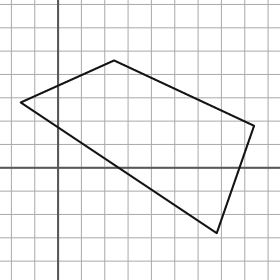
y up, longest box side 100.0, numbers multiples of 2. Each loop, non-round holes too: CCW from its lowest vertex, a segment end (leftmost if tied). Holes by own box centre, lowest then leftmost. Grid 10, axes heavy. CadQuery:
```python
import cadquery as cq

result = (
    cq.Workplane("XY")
    .moveTo(68.0, -28.0)
    .lineTo(84.0, 18.0)
    .lineTo(24.0, 46.0)
    .lineTo(-16.0, 28.0)
    .close()
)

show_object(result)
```